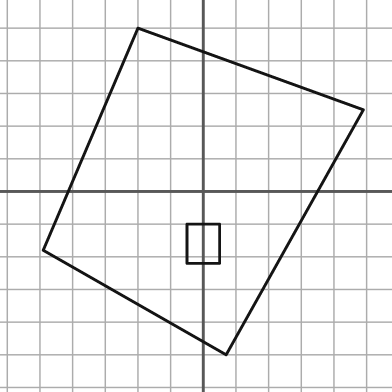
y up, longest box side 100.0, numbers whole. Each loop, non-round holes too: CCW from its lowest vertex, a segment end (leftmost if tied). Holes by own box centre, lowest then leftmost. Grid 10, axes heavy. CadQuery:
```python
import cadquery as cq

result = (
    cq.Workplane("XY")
    .moveTo(7.0, -50.0)
    .lineTo(49.0, 25.0)
    .lineTo(-20.0, 50.0)
    .lineTo(-49.0, -18.0)
    .close()
    .moveTo(-5.0, -22.0)
    .lineTo(5.0, -22.0)
    .lineTo(5.0, -10.0)
    .lineTo(-5.0, -10.0)
    .close()
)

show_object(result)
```